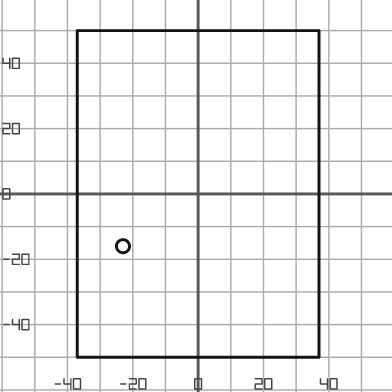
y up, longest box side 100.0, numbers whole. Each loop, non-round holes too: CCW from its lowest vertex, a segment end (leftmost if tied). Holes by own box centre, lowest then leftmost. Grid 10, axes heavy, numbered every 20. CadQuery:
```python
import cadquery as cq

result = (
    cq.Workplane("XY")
    .moveTo(-37.0, -50.0)
    .lineTo(37.0, -50.0)
    .lineTo(37.0, 50.0)
    .lineTo(-37.0, 50.0)
    .close()
    .moveTo(-23.0, -16.0)
    .circle(2.0)
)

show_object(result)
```